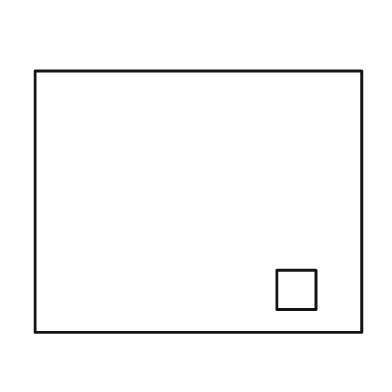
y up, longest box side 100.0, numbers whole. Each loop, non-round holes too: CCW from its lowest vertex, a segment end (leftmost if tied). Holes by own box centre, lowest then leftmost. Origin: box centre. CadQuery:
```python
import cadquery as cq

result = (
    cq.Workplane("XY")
    .moveTo(-50.0, -40.0)
    .lineTo(50.0, -40.0)
    .lineTo(50.0, 40.0)
    .lineTo(-50.0, 40.0)
    .close()
    .moveTo(24.0, -33.0)
    .lineTo(36.0, -33.0)
    .lineTo(36.0, -21.0)
    .lineTo(24.0, -21.0)
    .close()
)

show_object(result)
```